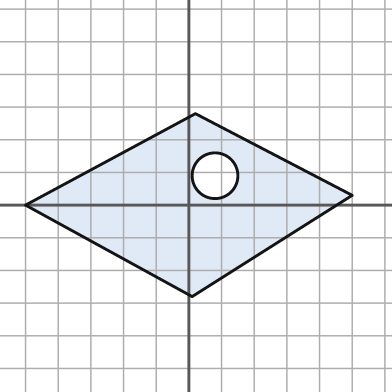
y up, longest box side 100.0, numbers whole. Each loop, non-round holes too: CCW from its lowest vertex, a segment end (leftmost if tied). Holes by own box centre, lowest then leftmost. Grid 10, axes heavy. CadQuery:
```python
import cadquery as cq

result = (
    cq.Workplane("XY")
    .moveTo(1.0, -28.0)
    .lineTo(50.0, 3.0)
    .lineTo(2.0, 28.0)
    .lineTo(-50.0, 0.0)
    .close()
    .moveTo(8.0, 9.0)
    .circle(7.0)
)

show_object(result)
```